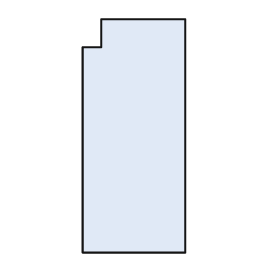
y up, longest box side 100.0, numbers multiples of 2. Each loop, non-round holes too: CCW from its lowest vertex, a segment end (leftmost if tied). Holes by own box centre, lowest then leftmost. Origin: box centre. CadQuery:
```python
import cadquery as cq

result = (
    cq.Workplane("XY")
    .moveTo(-22.0, -50.0)
    .lineTo(22.0, -50.0)
    .lineTo(22.0, 50.0)
    .lineTo(-14.0, 50.0)
    .lineTo(-14.0, 38.0)
    .lineTo(-22.0, 38.0)
    .close()
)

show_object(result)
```